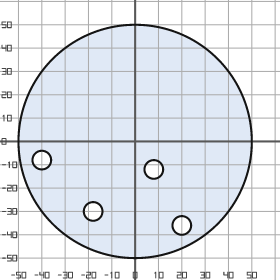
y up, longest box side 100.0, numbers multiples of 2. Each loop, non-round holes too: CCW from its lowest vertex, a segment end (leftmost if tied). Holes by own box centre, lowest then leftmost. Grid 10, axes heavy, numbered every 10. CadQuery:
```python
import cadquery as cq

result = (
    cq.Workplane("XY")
    .moveTo(0.0, 0.0)
    .circle(50.0)
    .moveTo(20.0, -36.0)
    .circle(4.0)
    .moveTo(-18.0, -30.0)
    .circle(4.0)
    .moveTo(8.0, -12.0)
    .circle(4.0)
    .moveTo(-40.0, -8.0)
    .circle(4.0)
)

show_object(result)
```